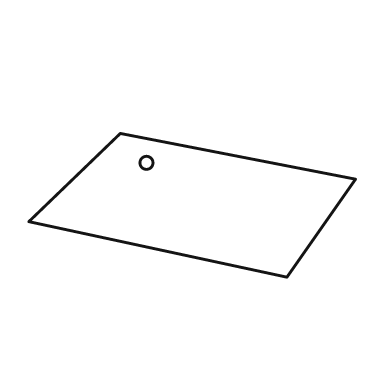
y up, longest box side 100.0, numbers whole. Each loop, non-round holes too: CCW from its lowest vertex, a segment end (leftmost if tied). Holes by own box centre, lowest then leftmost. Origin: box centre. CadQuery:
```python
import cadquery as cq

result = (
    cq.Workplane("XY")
    .moveTo(29.0, -22.0)
    .lineTo(50.0, 8.0)
    .lineTo(-22.0, 22.0)
    .lineTo(-50.0, -5.0)
    .close()
    .moveTo(-14.0, 13.0)
    .circle(2.0)
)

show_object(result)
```